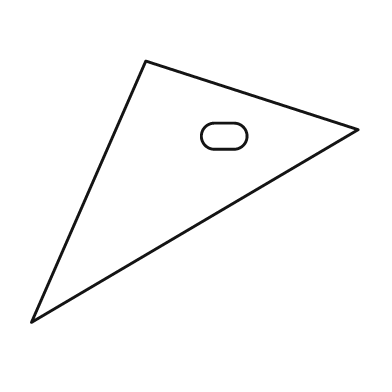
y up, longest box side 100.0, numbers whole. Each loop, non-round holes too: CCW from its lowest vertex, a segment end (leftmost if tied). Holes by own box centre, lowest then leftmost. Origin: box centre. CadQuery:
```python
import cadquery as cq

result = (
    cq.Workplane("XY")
    .moveTo(-50.0, -40.0)
    .lineTo(50.0, 19.0)
    .lineTo(-15.0, 40.0)
    .close()
    .moveTo(6.0, 13.0)
    .lineTo(12.0, 13.0)
    .threePointArc((16.0, 17.0), (12.0, 21.0))
    .lineTo(6.0, 21.0)
    .threePointArc((2.0, 17.0), (6.0, 13.0))
    .close()
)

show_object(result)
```